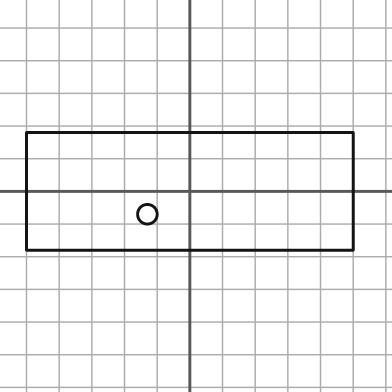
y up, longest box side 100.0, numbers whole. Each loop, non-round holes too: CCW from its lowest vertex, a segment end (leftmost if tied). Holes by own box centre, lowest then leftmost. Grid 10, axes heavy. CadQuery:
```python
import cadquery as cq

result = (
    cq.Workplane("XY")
    .moveTo(-50.0, -18.0)
    .lineTo(50.0, -18.0)
    .lineTo(50.0, 18.0)
    .lineTo(-50.0, 18.0)
    .close()
    .moveTo(-13.0, -7.0)
    .circle(3.0)
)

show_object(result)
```